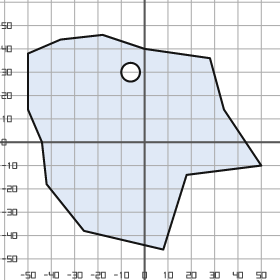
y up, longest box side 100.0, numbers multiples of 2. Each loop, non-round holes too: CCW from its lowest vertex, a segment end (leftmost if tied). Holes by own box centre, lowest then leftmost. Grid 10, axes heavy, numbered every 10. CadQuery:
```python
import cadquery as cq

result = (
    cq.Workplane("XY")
    .moveTo(8.0, -46.0)
    .lineTo(18.0, -14.0)
    .lineTo(50.0, -10.0)
    .lineTo(34.0, 14.0)
    .lineTo(28.0, 36.0)
    .lineTo(0.0, 40.0)
    .lineTo(-18.0, 46.0)
    .lineTo(-36.0, 44.0)
    .lineTo(-50.0, 38.0)
    .lineTo(-50.0, 14.0)
    .lineTo(-44.0, 0.0)
    .lineTo(-42.0, -18.0)
    .lineTo(-26.0, -38.0)
    .close()
    .moveTo(-6.0, 30.0)
    .circle(4.0)
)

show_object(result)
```